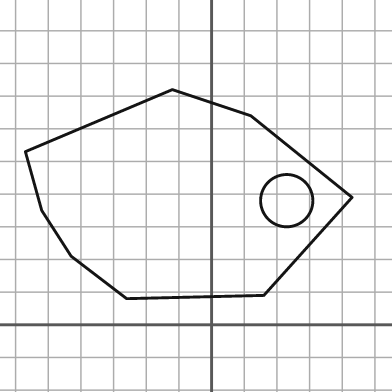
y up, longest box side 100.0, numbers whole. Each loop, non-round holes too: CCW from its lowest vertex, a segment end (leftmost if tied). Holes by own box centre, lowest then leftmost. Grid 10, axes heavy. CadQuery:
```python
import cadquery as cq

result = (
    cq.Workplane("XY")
    .moveTo(-26.0, 8.0)
    .lineTo(16.0, 9.0)
    .lineTo(43.0, 39.0)
    .lineTo(12.0, 64.0)
    .lineTo(-12.0, 72.0)
    .lineTo(-57.0, 53.0)
    .lineTo(-52.0, 35.0)
    .lineTo(-43.0, 21.0)
    .close()
    .moveTo(23.0, 38.0)
    .circle(8.0)
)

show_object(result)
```